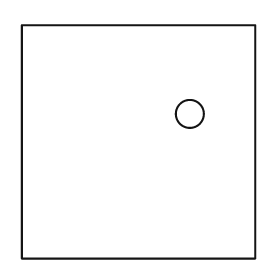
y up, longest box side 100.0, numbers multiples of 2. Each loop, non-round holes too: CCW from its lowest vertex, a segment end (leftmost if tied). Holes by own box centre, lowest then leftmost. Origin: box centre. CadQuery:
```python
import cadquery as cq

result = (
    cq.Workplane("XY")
    .moveTo(-50.0, -50.0)
    .lineTo(50.0, -50.0)
    .lineTo(50.0, 50.0)
    .lineTo(-50.0, 50.0)
    .close()
    .moveTo(22.0, 12.0)
    .circle(6.0)
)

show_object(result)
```